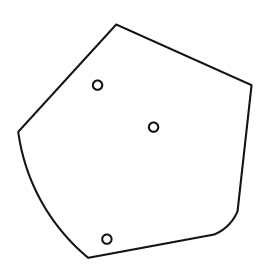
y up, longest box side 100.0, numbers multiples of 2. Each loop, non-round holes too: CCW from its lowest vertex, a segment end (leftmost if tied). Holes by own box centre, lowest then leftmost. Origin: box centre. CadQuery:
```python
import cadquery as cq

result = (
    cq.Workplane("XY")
    .moveTo(-20.0, -50.0)
    .lineTo(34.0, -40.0)
    .threePointArc((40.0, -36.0), (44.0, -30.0))
    .lineTo(50.0, 24.0)
    .lineTo(-8.0, 50.0)
    .lineTo(-50.0, 4.0)
    .threePointArc((-40.0, -26.0), (-20.0, -50.0))
    .close()
    .moveTo(-12.0, -42.0)
    .circle(2.0)
    .moveTo(8.0, 6.0)
    .circle(2.0)
    .moveTo(-16.0, 24.0)
    .circle(2.0)
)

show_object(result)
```